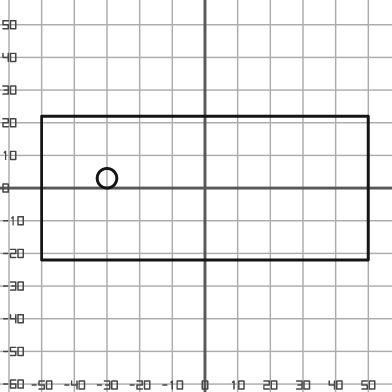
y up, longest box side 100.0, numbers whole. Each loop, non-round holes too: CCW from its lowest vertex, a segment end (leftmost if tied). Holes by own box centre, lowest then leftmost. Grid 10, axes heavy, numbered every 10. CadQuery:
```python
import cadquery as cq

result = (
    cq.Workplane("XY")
    .moveTo(-50.0, -22.0)
    .lineTo(50.0, -22.0)
    .lineTo(50.0, 22.0)
    .lineTo(-50.0, 22.0)
    .close()
    .moveTo(-30.0, 3.0)
    .circle(3.0)
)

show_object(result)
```